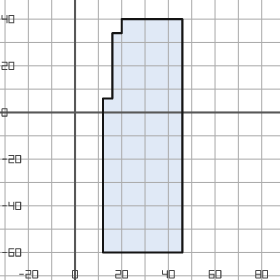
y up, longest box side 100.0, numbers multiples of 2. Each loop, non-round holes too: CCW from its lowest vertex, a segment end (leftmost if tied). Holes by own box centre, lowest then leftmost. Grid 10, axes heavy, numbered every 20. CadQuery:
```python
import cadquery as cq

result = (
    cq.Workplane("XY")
    .moveTo(12.0, -60.0)
    .lineTo(46.0, -60.0)
    .lineTo(46.0, 40.0)
    .lineTo(20.0, 40.0)
    .lineTo(20.0, 34.0)
    .lineTo(16.0, 34.0)
    .lineTo(16.0, 6.0)
    .lineTo(12.0, 6.0)
    .close()
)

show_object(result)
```